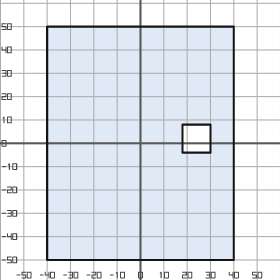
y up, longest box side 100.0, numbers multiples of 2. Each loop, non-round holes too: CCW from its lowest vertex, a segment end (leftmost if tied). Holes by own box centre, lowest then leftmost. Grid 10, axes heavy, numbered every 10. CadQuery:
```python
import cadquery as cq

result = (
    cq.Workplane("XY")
    .moveTo(-40.0, -50.0)
    .lineTo(40.0, -50.0)
    .lineTo(40.0, 50.0)
    .lineTo(-40.0, 50.0)
    .close()
    .moveTo(18.0, -4.0)
    .lineTo(30.0, -4.0)
    .lineTo(30.0, 8.0)
    .lineTo(18.0, 8.0)
    .close()
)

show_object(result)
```